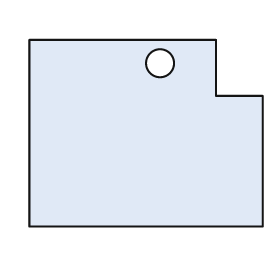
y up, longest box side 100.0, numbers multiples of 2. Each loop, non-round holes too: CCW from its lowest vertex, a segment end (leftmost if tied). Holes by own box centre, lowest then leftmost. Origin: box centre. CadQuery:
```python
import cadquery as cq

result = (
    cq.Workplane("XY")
    .moveTo(-50.0, -40.0)
    .lineTo(50.0, -40.0)
    .lineTo(50.0, 16.0)
    .lineTo(30.0, 16.0)
    .lineTo(30.0, 40.0)
    .lineTo(-50.0, 40.0)
    .close()
    .moveTo(6.0, 30.0)
    .circle(6.0)
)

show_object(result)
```